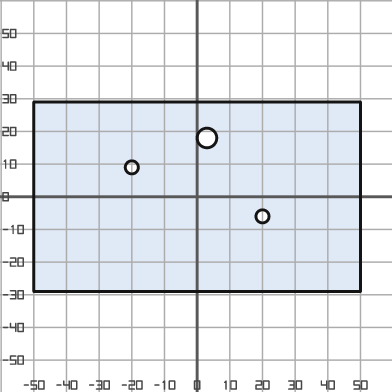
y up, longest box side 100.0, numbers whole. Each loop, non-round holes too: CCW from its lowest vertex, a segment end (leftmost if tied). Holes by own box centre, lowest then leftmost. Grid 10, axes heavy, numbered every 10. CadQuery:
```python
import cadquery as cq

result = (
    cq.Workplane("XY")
    .moveTo(-50.0, -29.0)
    .lineTo(50.0, -29.0)
    .lineTo(50.0, 29.0)
    .lineTo(-50.0, 29.0)
    .close()
    .moveTo(20.0, -6.0)
    .circle(2.0)
    .moveTo(-20.0, 9.0)
    .circle(2.0)
    .moveTo(3.0, 18.0)
    .circle(3.0)
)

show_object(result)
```